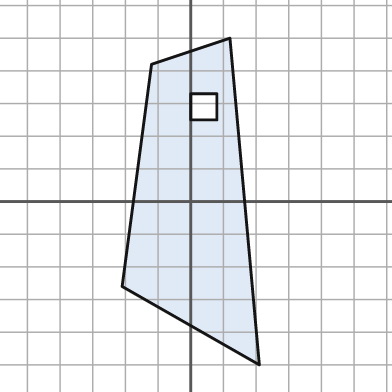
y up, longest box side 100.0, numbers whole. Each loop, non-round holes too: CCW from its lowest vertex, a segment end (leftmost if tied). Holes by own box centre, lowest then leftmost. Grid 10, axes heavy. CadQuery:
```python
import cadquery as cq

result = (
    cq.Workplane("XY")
    .moveTo(21.0, -50.0)
    .lineTo(12.0, 50.0)
    .lineTo(-12.0, 42.0)
    .lineTo(-21.0, -26.0)
    .close()
    .moveTo(0.0, 25.0)
    .lineTo(8.0, 25.0)
    .lineTo(8.0, 33.0)
    .lineTo(0.0, 33.0)
    .close()
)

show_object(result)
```